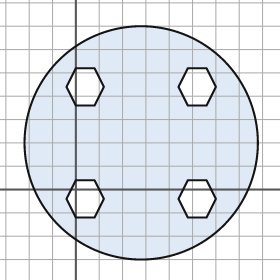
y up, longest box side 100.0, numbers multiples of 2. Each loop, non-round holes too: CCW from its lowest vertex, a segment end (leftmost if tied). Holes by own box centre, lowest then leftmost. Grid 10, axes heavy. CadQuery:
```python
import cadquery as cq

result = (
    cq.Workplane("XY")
    .moveTo(28.0, 20.0)
    .circle(50.0)
    .moveTo(0.0, -12.0)
    .lineTo(8.0, -12.0)
    .lineTo(12.0, -4.0)
    .lineTo(8.0, 4.0)
    .lineTo(0.0, 4.0)
    .lineTo(-4.0, -4.0)
    .close()
    .moveTo(48.0, -12.0)
    .lineTo(56.0, -12.0)
    .lineTo(60.0, -4.0)
    .lineTo(56.0, 4.0)
    .lineTo(48.0, 4.0)
    .lineTo(44.0, -4.0)
    .close()
    .moveTo(0.0, 36.0)
    .lineTo(8.0, 36.0)
    .lineTo(12.0, 44.0)
    .lineTo(8.0, 52.0)
    .lineTo(0.0, 52.0)
    .lineTo(-4.0, 44.0)
    .close()
    .moveTo(48.0, 36.0)
    .lineTo(56.0, 36.0)
    .lineTo(60.0, 44.0)
    .lineTo(56.0, 52.0)
    .lineTo(48.0, 52.0)
    .lineTo(44.0, 44.0)
    .close()
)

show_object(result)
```